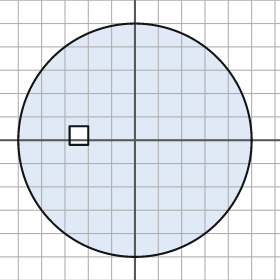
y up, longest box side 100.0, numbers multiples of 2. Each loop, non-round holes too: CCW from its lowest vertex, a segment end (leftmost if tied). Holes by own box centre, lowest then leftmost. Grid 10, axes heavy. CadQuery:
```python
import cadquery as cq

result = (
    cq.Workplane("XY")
    .moveTo(0.0, 0.0)
    .circle(50.0)
    .moveTo(-28.0, -2.0)
    .lineTo(-20.0, -2.0)
    .lineTo(-20.0, 6.0)
    .lineTo(-28.0, 6.0)
    .close()
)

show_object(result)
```